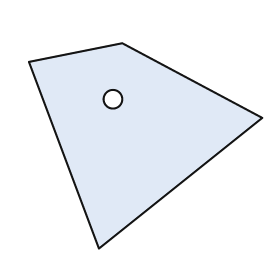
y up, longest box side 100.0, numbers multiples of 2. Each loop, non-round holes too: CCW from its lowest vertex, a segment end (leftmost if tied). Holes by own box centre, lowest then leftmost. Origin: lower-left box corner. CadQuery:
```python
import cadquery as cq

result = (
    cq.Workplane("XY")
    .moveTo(30.0, 0.0)
    .lineTo(100.0, 56.0)
    .lineTo(40.0, 88.0)
    .lineTo(0.0, 80.0)
    .close()
    .moveTo(36.0, 64.0)
    .circle(4.0)
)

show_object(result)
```